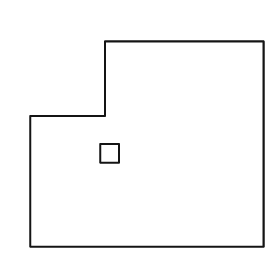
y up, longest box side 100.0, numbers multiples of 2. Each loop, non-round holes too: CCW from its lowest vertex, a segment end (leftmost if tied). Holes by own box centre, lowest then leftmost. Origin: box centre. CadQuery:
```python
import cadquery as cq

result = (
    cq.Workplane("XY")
    .moveTo(-50.0, -44.0)
    .lineTo(50.0, -44.0)
    .lineTo(50.0, 44.0)
    .lineTo(-18.0, 44.0)
    .lineTo(-18.0, 12.0)
    .lineTo(-50.0, 12.0)
    .close()
    .moveTo(-20.0, -8.0)
    .lineTo(-12.0, -8.0)
    .lineTo(-12.0, 0.0)
    .lineTo(-20.0, 0.0)
    .close()
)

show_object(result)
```